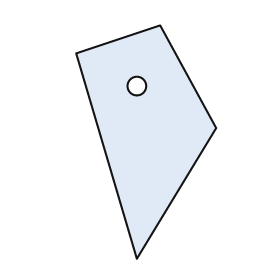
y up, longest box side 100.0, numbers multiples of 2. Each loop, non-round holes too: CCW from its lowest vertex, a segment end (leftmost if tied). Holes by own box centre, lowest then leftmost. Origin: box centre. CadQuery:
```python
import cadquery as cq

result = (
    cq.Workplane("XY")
    .moveTo(-4.0, -50.0)
    .lineTo(30.0, 6.0)
    .lineTo(6.0, 50.0)
    .lineTo(-30.0, 38.0)
    .close()
    .moveTo(-4.0, 24.0)
    .circle(4.0)
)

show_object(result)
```